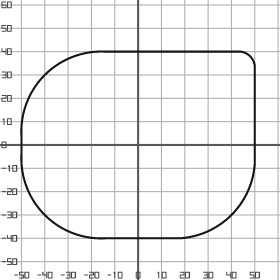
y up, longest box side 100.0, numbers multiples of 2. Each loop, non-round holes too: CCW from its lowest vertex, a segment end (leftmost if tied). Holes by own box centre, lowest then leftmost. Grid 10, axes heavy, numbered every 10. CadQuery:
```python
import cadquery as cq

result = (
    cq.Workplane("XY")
    .moveTo(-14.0, -40.0)
    .lineTo(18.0, -40.0)
    .threePointArc((40.0, -30.0), (50.0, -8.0))
    .lineTo(50.0, 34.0)
    .threePointArc((48.0, 38.0), (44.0, 40.0))
    .lineTo(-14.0, 40.0)
    .threePointArc((-40.0, 30.0), (-50.0, 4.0))
    .lineTo(-50.0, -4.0)
    .threePointArc((-40.0, -30.0), (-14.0, -40.0))
    .close()
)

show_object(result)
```